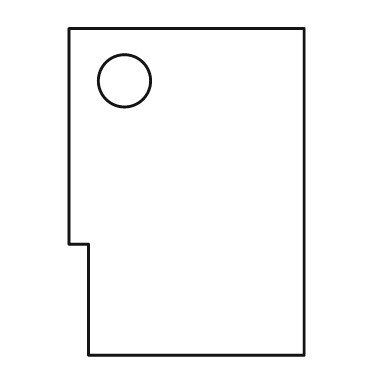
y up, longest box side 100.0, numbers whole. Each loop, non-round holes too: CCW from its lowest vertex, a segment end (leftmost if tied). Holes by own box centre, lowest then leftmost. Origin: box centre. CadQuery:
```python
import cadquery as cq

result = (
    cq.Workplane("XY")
    .moveTo(-30.0, -50.0)
    .lineTo(36.0, -50.0)
    .lineTo(36.0, 50.0)
    .lineTo(-36.0, 50.0)
    .lineTo(-36.0, -16.0)
    .lineTo(-30.0, -16.0)
    .close()
    .moveTo(-19.0, 34.0)
    .circle(8.0)
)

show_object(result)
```